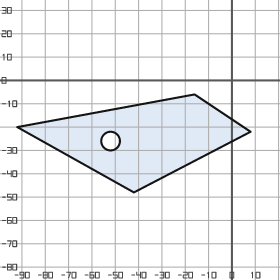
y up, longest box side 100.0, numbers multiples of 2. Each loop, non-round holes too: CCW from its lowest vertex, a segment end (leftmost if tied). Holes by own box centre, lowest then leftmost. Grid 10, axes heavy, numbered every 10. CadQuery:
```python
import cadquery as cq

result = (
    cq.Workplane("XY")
    .moveTo(-42.0, -48.0)
    .lineTo(8.0, -22.0)
    .lineTo(-16.0, -6.0)
    .lineTo(-92.0, -20.0)
    .close()
    .moveTo(-52.0, -26.0)
    .circle(4.0)
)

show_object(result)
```